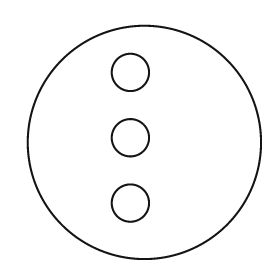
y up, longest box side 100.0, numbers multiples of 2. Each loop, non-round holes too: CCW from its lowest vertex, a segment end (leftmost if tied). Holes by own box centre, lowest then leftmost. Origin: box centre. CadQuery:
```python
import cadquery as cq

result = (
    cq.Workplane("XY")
    .moveTo(0.0, 0.0)
    .circle(50.0)
    .moveTo(-6.0, -26.0)
    .circle(8.0)
    .moveTo(-6.0, 2.0)
    .circle(8.0)
    .moveTo(-6.0, 30.0)
    .circle(8.0)
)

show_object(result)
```